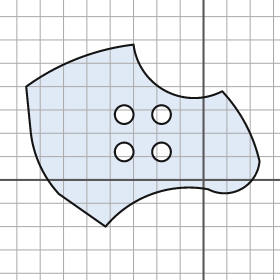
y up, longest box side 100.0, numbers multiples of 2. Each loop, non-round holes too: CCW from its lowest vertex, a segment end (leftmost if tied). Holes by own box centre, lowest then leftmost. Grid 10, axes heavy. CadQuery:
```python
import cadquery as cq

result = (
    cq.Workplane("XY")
    .moveTo(-42.0, -20.0)
    .threePointArc((-22.0, -6.0), (2.0, -4.0))
    .threePointArc((16.0, -4.0), (24.0, 8.0))
    .threePointArc((18.0, 24.0), (8.0, 38.0))
    .threePointArc((-16.0, 38.0), (-30.0, 58.0))
    .threePointArc((-54.0, 52.0), (-76.0, 40.0))
    .lineTo(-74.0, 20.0)
    .threePointArc((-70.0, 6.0), (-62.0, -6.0))
    .close()
    .moveTo(-34.0, 12.0)
    .circle(4.0)
    .moveTo(-18.0, 12.0)
    .circle(4.0)
    .moveTo(-34.0, 28.0)
    .circle(4.0)
    .moveTo(-18.0, 28.0)
    .circle(4.0)
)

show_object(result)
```